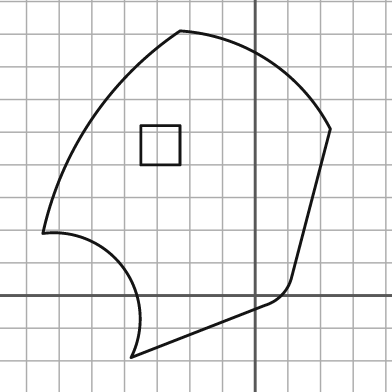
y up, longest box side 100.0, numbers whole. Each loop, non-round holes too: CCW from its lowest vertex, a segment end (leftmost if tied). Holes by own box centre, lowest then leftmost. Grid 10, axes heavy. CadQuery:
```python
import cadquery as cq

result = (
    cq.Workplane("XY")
    .moveTo(-38.0, -19.0)
    .lineTo(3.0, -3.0)
    .threePointArc((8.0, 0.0), (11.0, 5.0))
    .lineTo(23.0, 51.0)
    .threePointArc((4.0, 72.0), (-23.0, 81.0))
    .threePointArc((-50.0, 54.0), (-65.0, 19.0))
    .threePointArc((-40.0, 8.0), (-38.0, -19.0))
    .close()
    .moveTo(-35.0, 40.0)
    .lineTo(-23.0, 40.0)
    .lineTo(-23.0, 52.0)
    .lineTo(-35.0, 52.0)
    .close()
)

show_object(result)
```